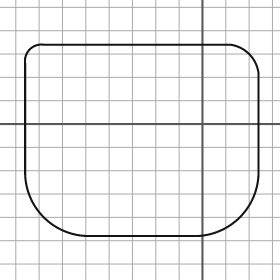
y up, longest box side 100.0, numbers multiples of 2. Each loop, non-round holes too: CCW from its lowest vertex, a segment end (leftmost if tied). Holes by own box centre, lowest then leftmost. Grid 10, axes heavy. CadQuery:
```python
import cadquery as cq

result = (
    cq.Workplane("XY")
    .moveTo(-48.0, -48.0)
    .lineTo(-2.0, -48.0)
    .threePointArc((16.0, -40.0), (24.0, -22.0))
    .lineTo(24.0, 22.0)
    .threePointArc((20.0, 30.0), (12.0, 34.0))
    .lineTo(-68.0, 34.0)
    .threePointArc((-74.0, 32.0), (-76.0, 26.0))
    .lineTo(-76.0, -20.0)
    .threePointArc((-68.0, -40.0), (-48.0, -48.0))
    .close()
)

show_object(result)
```